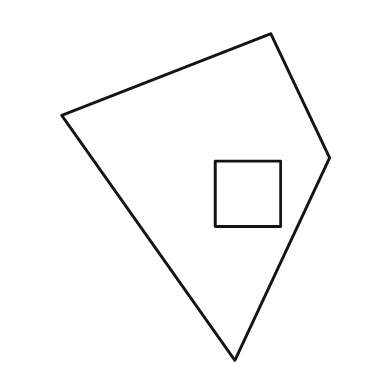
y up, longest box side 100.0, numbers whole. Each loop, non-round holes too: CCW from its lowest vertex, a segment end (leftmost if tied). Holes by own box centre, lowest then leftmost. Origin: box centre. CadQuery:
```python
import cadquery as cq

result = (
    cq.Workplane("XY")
    .moveTo(12.0, -50.0)
    .lineTo(41.0, 12.0)
    .lineTo(23.0, 50.0)
    .lineTo(-41.0, 25.0)
    .close()
    .moveTo(6.0, -9.0)
    .lineTo(26.0, -9.0)
    .lineTo(26.0, 11.0)
    .lineTo(6.0, 11.0)
    .close()
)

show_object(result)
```